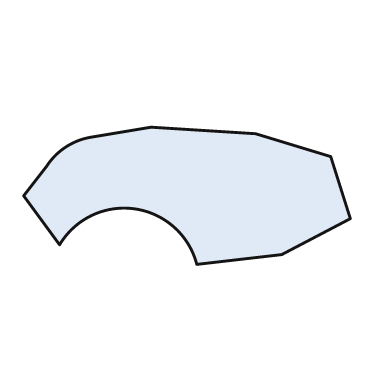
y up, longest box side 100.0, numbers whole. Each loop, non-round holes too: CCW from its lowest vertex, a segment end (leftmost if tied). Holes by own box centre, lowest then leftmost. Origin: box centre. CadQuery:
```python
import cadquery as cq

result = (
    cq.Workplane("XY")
    .moveTo(3.0, -21.0)
    .lineTo(29.0, -18.0)
    .lineTo(50.0, -7.0)
    .lineTo(44.0, 12.0)
    .lineTo(21.0, 19.0)
    .lineTo(-11.0, 21.0)
    .lineTo(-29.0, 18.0)
    .threePointArc((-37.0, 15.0), (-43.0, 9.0))
    .lineTo(-50.0, 0.0)
    .lineTo(-39.0, -15.0)
    .threePointArc((-16.0, -4.0), (3.0, -21.0))
    .close()
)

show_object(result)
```